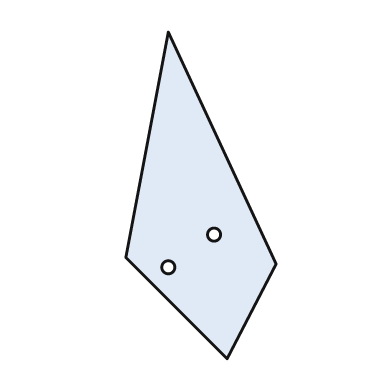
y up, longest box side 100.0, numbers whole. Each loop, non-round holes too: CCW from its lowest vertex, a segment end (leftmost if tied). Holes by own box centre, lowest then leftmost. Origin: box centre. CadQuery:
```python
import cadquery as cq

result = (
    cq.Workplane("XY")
    .moveTo(8.0, -50.0)
    .lineTo(23.0, -21.0)
    .lineTo(-10.0, 50.0)
    .lineTo(-23.0, -19.0)
    .close()
    .moveTo(-10.0, -22.0)
    .circle(2.0)
    .moveTo(4.0, -12.0)
    .circle(2.0)
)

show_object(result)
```